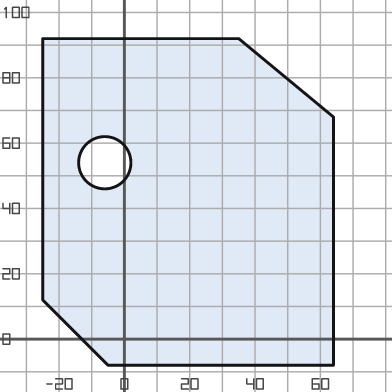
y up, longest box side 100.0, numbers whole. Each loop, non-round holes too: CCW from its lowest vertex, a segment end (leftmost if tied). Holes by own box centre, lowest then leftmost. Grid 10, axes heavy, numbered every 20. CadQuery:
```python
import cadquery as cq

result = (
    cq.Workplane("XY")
    .moveTo(-5.0, -8.0)
    .lineTo(64.0, -8.0)
    .lineTo(64.0, 68.0)
    .lineTo(35.0, 92.0)
    .lineTo(-25.0, 92.0)
    .lineTo(-25.0, 12.0)
    .close()
    .moveTo(-6.0, 54.0)
    .circle(8.0)
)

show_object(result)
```